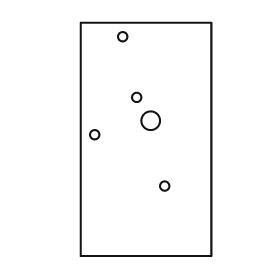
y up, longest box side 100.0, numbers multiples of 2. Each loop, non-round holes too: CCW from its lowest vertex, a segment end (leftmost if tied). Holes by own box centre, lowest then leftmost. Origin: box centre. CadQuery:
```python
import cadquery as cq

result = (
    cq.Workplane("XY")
    .moveTo(-28.0, -50.0)
    .lineTo(28.0, -50.0)
    .lineTo(28.0, 50.0)
    .lineTo(-28.0, 50.0)
    .close()
    .moveTo(8.0, -20.0)
    .circle(2.0)
    .moveTo(-22.0, 2.0)
    .circle(2.0)
    .moveTo(2.0, 8.0)
    .circle(4.0)
    .moveTo(-4.0, 18.0)
    .circle(2.0)
    .moveTo(-10.0, 44.0)
    .circle(2.0)
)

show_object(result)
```